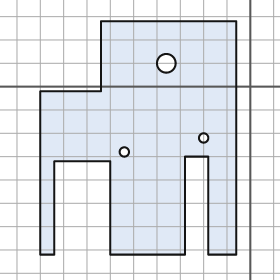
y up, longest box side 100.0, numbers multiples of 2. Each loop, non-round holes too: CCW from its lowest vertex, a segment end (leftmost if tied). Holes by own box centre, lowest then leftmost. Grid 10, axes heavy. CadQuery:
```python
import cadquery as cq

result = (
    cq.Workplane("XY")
    .moveTo(-90.0, -72.0)
    .lineTo(-84.0, -72.0)
    .lineTo(-84.0, -32.0)
    .lineTo(-60.0, -32.0)
    .lineTo(-60.0, -72.0)
    .lineTo(-28.0, -72.0)
    .lineTo(-28.0, -30.0)
    .lineTo(-18.0, -30.0)
    .lineTo(-18.0, -72.0)
    .lineTo(-6.0, -72.0)
    .lineTo(-6.0, 28.0)
    .lineTo(-64.0, 28.0)
    .lineTo(-64.0, -2.0)
    .lineTo(-90.0, -2.0)
    .close()
    .moveTo(-54.0, -28.0)
    .circle(2.0)
    .moveTo(-20.0, -22.0)
    .circle(2.0)
    .moveTo(-36.0, 10.0)
    .circle(4.0)
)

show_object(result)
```